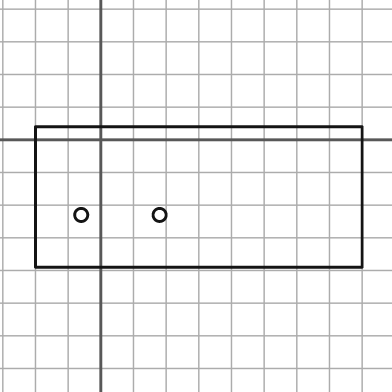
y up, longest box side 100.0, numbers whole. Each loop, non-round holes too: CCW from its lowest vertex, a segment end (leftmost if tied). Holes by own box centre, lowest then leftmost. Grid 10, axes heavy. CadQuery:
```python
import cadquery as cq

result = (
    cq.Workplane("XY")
    .moveTo(-20.0, -39.0)
    .lineTo(80.0, -39.0)
    .lineTo(80.0, 4.0)
    .lineTo(-20.0, 4.0)
    .close()
    .moveTo(-6.0, -23.0)
    .circle(2.0)
    .moveTo(18.0, -23.0)
    .circle(2.0)
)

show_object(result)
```